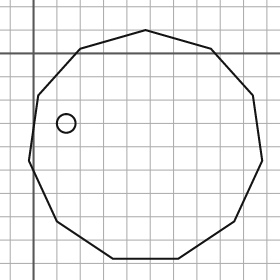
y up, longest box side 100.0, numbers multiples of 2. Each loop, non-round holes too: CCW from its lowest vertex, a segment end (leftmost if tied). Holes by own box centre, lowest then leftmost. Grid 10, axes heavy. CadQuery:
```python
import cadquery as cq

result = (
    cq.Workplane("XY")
    .moveTo(34.0, -88.0)
    .lineTo(62.0, -88.0)
    .lineTo(86.0, -72.0)
    .lineTo(98.0, -46.0)
    .lineTo(94.0, -18.0)
    .lineTo(76.0, 2.0)
    .lineTo(48.0, 10.0)
    .lineTo(20.0, 2.0)
    .lineTo(2.0, -18.0)
    .lineTo(-2.0, -46.0)
    .lineTo(10.0, -72.0)
    .close()
    .moveTo(14.0, -30.0)
    .circle(4.0)
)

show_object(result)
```